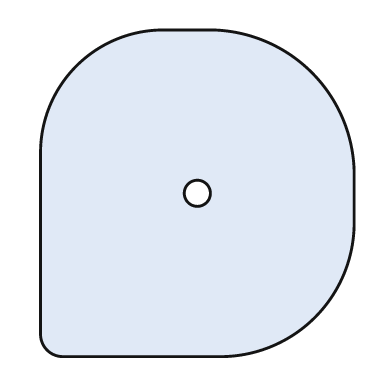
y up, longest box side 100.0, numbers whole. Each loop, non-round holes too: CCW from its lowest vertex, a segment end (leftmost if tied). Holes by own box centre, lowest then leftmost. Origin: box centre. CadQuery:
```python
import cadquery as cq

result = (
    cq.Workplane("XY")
    .moveTo(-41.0, -50.0)
    .lineTo(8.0, -50.0)
    .threePointArc((36.0, -38.0), (48.0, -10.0))
    .lineTo(48.0, 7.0)
    .threePointArc((35.0, 37.0), (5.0, 50.0))
    .lineTo(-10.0, 50.0)
    .threePointArc((-37.0, 39.0), (-48.0, 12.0))
    .lineTo(-48.0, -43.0)
    .threePointArc((-46.0, -48.0), (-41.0, -50.0))
    .close()
    .moveTo(0.0, 0.0)
    .circle(4.0)
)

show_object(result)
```